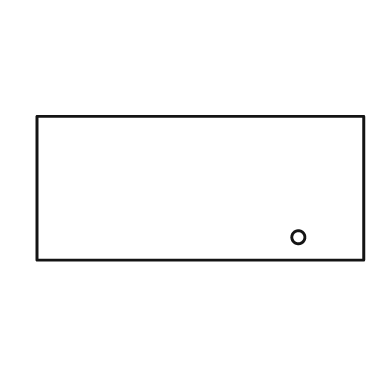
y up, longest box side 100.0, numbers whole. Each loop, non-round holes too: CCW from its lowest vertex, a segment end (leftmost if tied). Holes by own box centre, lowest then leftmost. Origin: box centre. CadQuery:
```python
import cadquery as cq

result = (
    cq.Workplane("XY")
    .moveTo(-50.0, -22.0)
    .lineTo(50.0, -22.0)
    .lineTo(50.0, 22.0)
    .lineTo(-50.0, 22.0)
    .close()
    .moveTo(30.0, -15.0)
    .circle(2.0)
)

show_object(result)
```